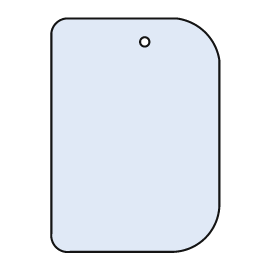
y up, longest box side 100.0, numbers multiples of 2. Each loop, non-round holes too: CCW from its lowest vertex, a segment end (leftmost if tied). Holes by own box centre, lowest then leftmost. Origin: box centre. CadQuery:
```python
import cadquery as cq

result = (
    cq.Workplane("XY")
    .moveTo(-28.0, -50.0)
    .lineTo(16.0, -50.0)
    .threePointArc((30.0, -44.0), (36.0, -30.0))
    .lineTo(36.0, 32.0)
    .threePointArc((30.0, 44.0), (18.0, 50.0))
    .lineTo(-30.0, 50.0)
    .threePointArc((-34.0, 48.0), (-36.0, 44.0))
    .lineTo(-36.0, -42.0)
    .threePointArc((-34.0, -48.0), (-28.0, -50.0))
    .close()
    .moveTo(4.0, 40.0)
    .circle(2.0)
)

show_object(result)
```